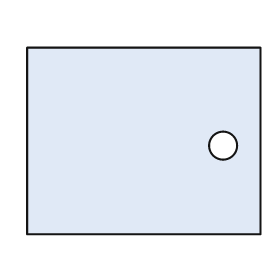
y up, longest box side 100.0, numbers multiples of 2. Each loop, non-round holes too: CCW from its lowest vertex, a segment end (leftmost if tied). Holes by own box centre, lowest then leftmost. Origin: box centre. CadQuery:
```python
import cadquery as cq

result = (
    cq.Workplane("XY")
    .moveTo(-50.0, -40.0)
    .lineTo(50.0, -40.0)
    .lineTo(50.0, 40.0)
    .lineTo(-50.0, 40.0)
    .close()
    .moveTo(34.0, -2.0)
    .circle(6.0)
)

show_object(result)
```